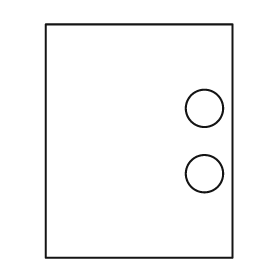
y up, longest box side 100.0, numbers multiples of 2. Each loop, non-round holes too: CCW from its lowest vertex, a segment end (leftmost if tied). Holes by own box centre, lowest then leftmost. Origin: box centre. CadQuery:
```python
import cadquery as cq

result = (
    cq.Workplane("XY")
    .moveTo(-40.0, -50.0)
    .lineTo(40.0, -50.0)
    .lineTo(40.0, 50.0)
    .lineTo(-40.0, 50.0)
    .close()
    .moveTo(28.0, -14.0)
    .circle(8.0)
    .moveTo(28.0, 14.0)
    .circle(8.0)
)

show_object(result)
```